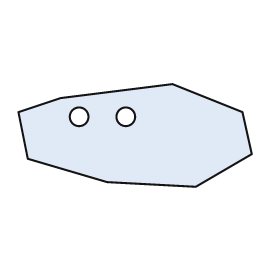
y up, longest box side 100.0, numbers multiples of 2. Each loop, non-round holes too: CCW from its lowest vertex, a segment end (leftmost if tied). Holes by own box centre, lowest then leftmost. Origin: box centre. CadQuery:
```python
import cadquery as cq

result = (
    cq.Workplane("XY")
    .moveTo(26.0, -22.0)
    .lineTo(50.0, -8.0)
    .lineTo(46.0, 10.0)
    .lineTo(16.0, 22.0)
    .lineTo(-32.0, 16.0)
    .lineTo(-50.0, 10.0)
    .lineTo(-46.0, -10.0)
    .lineTo(-12.0, -20.0)
    .close()
    .moveTo(-24.0, 8.0)
    .circle(4.0)
    .moveTo(-4.0, 8.0)
    .circle(4.0)
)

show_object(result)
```